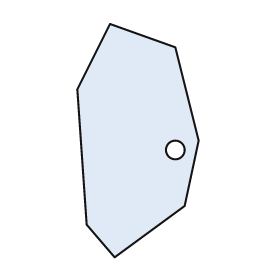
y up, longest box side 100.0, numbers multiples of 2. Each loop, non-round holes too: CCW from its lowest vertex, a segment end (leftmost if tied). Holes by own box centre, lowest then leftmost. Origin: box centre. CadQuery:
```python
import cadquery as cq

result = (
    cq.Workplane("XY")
    .moveTo(-10.0, -50.0)
    .lineTo(20.0, -28.0)
    .lineTo(26.0, 0.0)
    .lineTo(16.0, 40.0)
    .lineTo(-12.0, 50.0)
    .lineTo(-26.0, 22.0)
    .lineTo(-22.0, -36.0)
    .close()
    .moveTo(16.0, -4.0)
    .circle(4.0)
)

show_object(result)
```